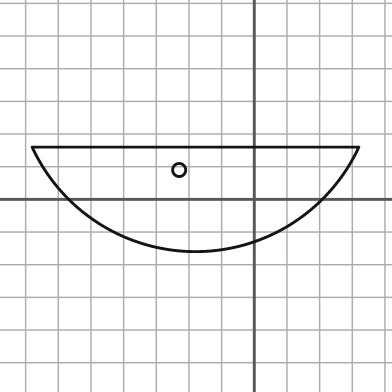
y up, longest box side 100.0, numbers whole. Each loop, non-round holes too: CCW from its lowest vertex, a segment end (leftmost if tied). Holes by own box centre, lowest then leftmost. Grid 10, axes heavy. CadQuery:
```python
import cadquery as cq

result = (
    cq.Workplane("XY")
    .moveTo(-68.0, 16.0)
    .threePointArc((-18.0, -16.0), (32.0, 16.0))
    .close()
    .moveTo(-23.0, 9.0)
    .circle(2.0)
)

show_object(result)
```